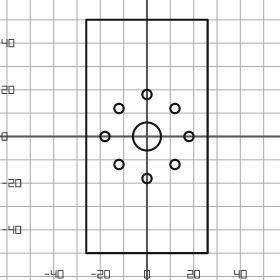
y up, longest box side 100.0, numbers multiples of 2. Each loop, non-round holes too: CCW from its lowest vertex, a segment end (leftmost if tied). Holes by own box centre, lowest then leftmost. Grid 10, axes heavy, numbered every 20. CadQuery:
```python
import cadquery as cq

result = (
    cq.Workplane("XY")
    .moveTo(-26.0, -50.0)
    .lineTo(26.0, -50.0)
    .lineTo(26.0, 50.0)
    .lineTo(-26.0, 50.0)
    .close()
    .moveTo(0.0, -18.0)
    .circle(2.0)
    .moveTo(-12.0, -12.0)
    .circle(2.0)
    .moveTo(12.0, -12.0)
    .circle(2.0)
    .moveTo(-18.0, 0.0)
    .circle(2.0)
    .moveTo(0.0, 0.0)
    .circle(6.0)
    .moveTo(18.0, 0.0)
    .circle(2.0)
    .moveTo(-12.0, 12.0)
    .circle(2.0)
    .moveTo(12.0, 12.0)
    .circle(2.0)
    .moveTo(0.0, 18.0)
    .circle(2.0)
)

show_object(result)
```